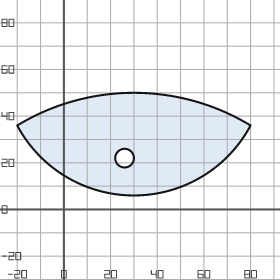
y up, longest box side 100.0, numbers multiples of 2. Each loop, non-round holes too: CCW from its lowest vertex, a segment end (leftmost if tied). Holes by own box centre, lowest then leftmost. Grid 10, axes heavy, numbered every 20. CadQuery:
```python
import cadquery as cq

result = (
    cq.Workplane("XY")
    .moveTo(-20.0, 36.0)
    .threePointArc((30.0, 6.0), (80.0, 36.0))
    .threePointArc((30.0, 50.0), (-20.0, 36.0))
    .close()
    .moveTo(26.0, 22.0)
    .circle(4.0)
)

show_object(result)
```